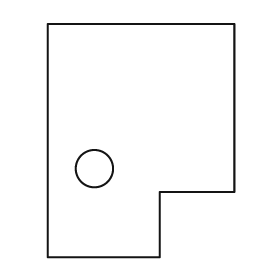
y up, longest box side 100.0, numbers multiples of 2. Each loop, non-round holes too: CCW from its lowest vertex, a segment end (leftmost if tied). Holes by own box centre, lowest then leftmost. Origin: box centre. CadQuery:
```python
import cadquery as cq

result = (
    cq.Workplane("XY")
    .moveTo(-40.0, -50.0)
    .lineTo(8.0, -50.0)
    .lineTo(8.0, -22.0)
    .lineTo(40.0, -22.0)
    .lineTo(40.0, 50.0)
    .lineTo(-40.0, 50.0)
    .close()
    .moveTo(-20.0, -12.0)
    .circle(8.0)
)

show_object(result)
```